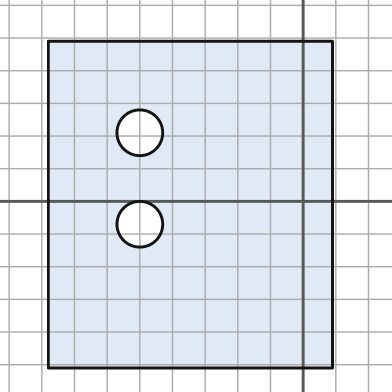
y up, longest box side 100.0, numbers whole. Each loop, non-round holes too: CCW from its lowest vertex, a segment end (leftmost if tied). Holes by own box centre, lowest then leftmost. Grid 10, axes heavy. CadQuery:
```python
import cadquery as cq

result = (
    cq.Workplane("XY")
    .moveTo(-78.0, -51.0)
    .lineTo(9.0, -51.0)
    .lineTo(9.0, 49.0)
    .lineTo(-78.0, 49.0)
    .close()
    .moveTo(-50.0, -7.0)
    .circle(7.0)
    .moveTo(-50.0, 21.0)
    .circle(7.0)
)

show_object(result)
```